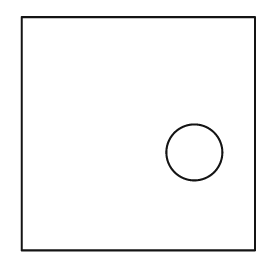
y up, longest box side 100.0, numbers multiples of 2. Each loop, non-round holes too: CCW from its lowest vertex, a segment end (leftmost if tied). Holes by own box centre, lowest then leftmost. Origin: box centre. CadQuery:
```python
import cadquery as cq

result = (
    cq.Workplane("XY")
    .moveTo(-50.0, -50.0)
    .lineTo(50.0, -50.0)
    .lineTo(50.0, 50.0)
    .lineTo(-50.0, 50.0)
    .close()
    .moveTo(24.0, -8.0)
    .circle(12.0)
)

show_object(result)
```